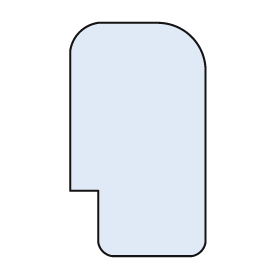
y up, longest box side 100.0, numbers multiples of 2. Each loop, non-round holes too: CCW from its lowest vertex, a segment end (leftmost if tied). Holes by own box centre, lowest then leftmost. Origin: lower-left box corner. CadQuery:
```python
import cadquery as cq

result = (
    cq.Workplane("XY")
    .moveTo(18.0, 0.0)
    .lineTo(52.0, 0.0)
    .threePointArc((56.0, 2.0), (58.0, 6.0))
    .lineTo(58.0, 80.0)
    .threePointArc((52.0, 94.0), (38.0, 100.0))
    .lineTo(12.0, 100.0)
    .threePointArc((4.0, 96.0), (0.0, 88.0))
    .lineTo(0.0, 28.0)
    .lineTo(12.0, 28.0)
    .lineTo(12.0, 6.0)
    .threePointArc((14.0, 2.0), (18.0, 0.0))
    .close()
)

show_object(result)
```